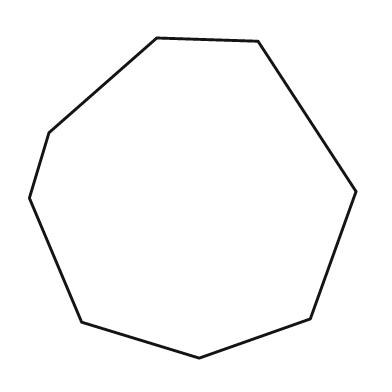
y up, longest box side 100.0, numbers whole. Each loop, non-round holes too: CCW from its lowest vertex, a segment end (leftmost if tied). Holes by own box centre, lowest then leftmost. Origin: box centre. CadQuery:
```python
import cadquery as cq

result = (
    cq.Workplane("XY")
    .moveTo(2.0, -49.0)
    .lineTo(36.0, -37.0)
    .lineTo(50.0, 2.0)
    .lineTo(20.0, 48.0)
    .lineTo(-11.0, 49.0)
    .lineTo(-44.0, 20.0)
    .lineTo(-50.0, 0.0)
    .lineTo(-34.0, -38.0)
    .close()
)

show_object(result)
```